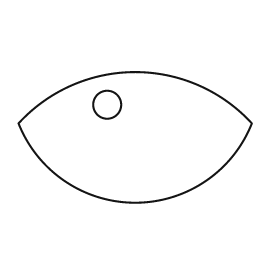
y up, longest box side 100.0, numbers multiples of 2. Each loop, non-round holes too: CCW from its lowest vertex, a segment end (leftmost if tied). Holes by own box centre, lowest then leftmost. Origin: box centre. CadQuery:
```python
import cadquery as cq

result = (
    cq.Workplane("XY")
    .moveTo(-50.0, 6.0)
    .threePointArc((0.0, -28.0), (50.0, 6.0))
    .threePointArc((0.0, 28.0), (-50.0, 6.0))
    .close()
    .moveTo(-12.0, 14.0)
    .circle(6.0)
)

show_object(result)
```